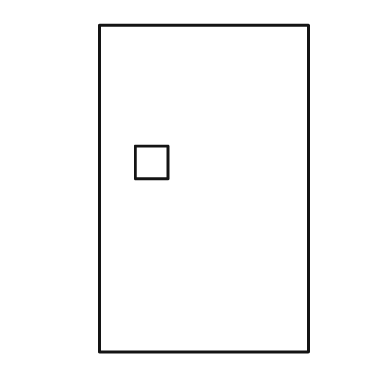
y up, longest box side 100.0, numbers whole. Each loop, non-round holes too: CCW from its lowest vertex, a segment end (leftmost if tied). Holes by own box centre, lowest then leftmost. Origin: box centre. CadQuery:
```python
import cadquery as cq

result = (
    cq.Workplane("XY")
    .moveTo(-32.0, -50.0)
    .lineTo(32.0, -50.0)
    .lineTo(32.0, 50.0)
    .lineTo(-32.0, 50.0)
    .close()
    .moveTo(-21.0, 3.0)
    .lineTo(-11.0, 3.0)
    .lineTo(-11.0, 13.0)
    .lineTo(-21.0, 13.0)
    .close()
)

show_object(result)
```